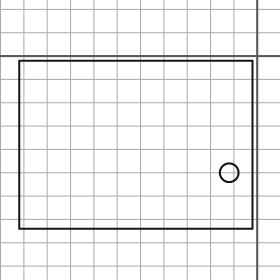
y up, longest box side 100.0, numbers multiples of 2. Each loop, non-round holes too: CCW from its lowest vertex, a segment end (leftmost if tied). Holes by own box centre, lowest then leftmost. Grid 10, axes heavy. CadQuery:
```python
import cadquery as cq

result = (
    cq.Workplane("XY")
    .moveTo(-102.0, -74.0)
    .lineTo(-2.0, -74.0)
    .lineTo(-2.0, -2.0)
    .lineTo(-102.0, -2.0)
    .close()
    .moveTo(-12.0, -50.0)
    .circle(4.0)
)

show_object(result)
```